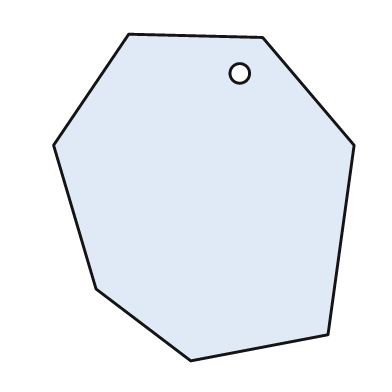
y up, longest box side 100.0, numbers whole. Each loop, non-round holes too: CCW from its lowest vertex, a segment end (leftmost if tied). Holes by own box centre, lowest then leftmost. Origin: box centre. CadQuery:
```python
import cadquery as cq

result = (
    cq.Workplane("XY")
    .moveTo(-4.0, -50.0)
    .lineTo(38.0, -42.0)
    .lineTo(46.0, 16.0)
    .lineTo(18.0, 49.0)
    .lineTo(-23.0, 50.0)
    .lineTo(-46.0, 16.0)
    .lineTo(-33.0, -28.0)
    .close()
    .moveTo(11.0, 38.0)
    .circle(3.0)
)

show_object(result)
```